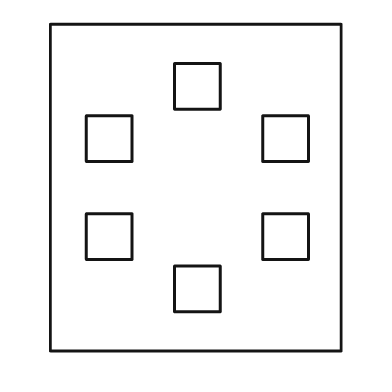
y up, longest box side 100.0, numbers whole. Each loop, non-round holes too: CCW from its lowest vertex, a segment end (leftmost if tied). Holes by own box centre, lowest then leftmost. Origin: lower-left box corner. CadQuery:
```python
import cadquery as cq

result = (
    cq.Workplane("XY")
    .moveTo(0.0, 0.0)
    .lineTo(89.0, 0.0)
    .lineTo(89.0, 100.0)
    .lineTo(0.0, 100.0)
    .close()
    .moveTo(38.0, 12.0)
    .lineTo(52.0, 12.0)
    .lineTo(52.0, 26.0)
    .lineTo(38.0, 26.0)
    .close()
    .moveTo(11.0, 28.0)
    .lineTo(25.0, 28.0)
    .lineTo(25.0, 42.0)
    .lineTo(11.0, 42.0)
    .close()
    .moveTo(65.0, 28.0)
    .lineTo(79.0, 28.0)
    .lineTo(79.0, 42.0)
    .lineTo(65.0, 42.0)
    .close()
    .moveTo(11.0, 58.0)
    .lineTo(25.0, 58.0)
    .lineTo(25.0, 72.0)
    .lineTo(11.0, 72.0)
    .close()
    .moveTo(65.0, 58.0)
    .lineTo(79.0, 58.0)
    .lineTo(79.0, 72.0)
    .lineTo(65.0, 72.0)
    .close()
    .moveTo(38.0, 74.0)
    .lineTo(52.0, 74.0)
    .lineTo(52.0, 88.0)
    .lineTo(38.0, 88.0)
    .close()
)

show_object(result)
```